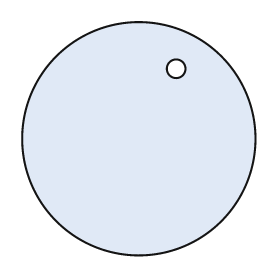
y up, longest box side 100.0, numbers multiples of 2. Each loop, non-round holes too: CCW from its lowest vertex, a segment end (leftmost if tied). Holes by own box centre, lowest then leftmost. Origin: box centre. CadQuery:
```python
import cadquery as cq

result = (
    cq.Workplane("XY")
    .moveTo(0.0, 0.0)
    .circle(50.0)
    .moveTo(16.0, 30.0)
    .circle(4.0)
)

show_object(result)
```